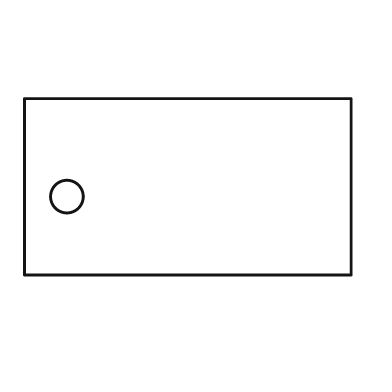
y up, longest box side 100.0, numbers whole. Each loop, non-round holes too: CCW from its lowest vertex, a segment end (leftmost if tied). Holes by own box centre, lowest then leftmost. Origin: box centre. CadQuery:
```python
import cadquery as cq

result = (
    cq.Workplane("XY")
    .moveTo(-50.0, -27.0)
    .lineTo(50.0, -27.0)
    .lineTo(50.0, 27.0)
    .lineTo(-50.0, 27.0)
    .close()
    .moveTo(-37.0, -3.0)
    .circle(5.0)
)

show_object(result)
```